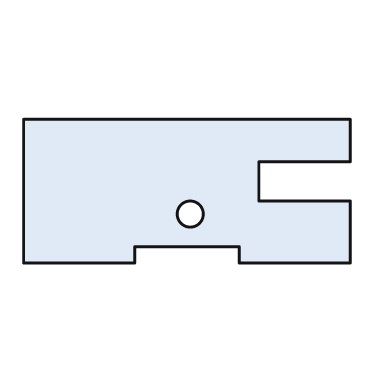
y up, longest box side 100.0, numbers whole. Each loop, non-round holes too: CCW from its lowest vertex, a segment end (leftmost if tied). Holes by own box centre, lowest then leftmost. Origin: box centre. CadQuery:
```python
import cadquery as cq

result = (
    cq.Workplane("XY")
    .moveTo(-50.0, -22.0)
    .lineTo(-16.0, -22.0)
    .lineTo(-16.0, -17.0)
    .lineTo(16.0, -17.0)
    .lineTo(16.0, -22.0)
    .lineTo(50.0, -22.0)
    .lineTo(50.0, -3.0)
    .lineTo(22.0, -3.0)
    .lineTo(22.0, 9.0)
    .lineTo(50.0, 9.0)
    .lineTo(50.0, 22.0)
    .lineTo(-50.0, 22.0)
    .close()
    .moveTo(1.0, -7.0)
    .circle(4.0)
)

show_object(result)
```